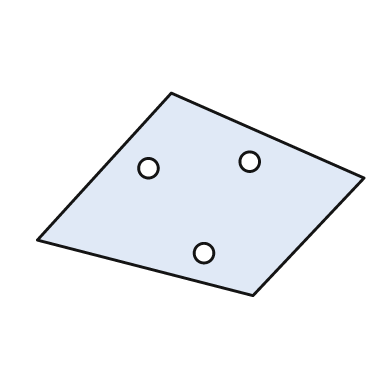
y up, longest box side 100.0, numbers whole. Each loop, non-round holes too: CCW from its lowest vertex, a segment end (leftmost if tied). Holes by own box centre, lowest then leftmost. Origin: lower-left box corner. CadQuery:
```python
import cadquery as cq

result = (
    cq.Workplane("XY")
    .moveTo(66.0, 0.0)
    .lineTo(100.0, 36.0)
    .lineTo(41.0, 62.0)
    .lineTo(0.0, 17.0)
    .close()
    .moveTo(51.0, 13.0)
    .circle(3.0)
    .moveTo(34.0, 39.0)
    .circle(3.0)
    .moveTo(65.0, 41.0)
    .circle(3.0)
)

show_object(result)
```